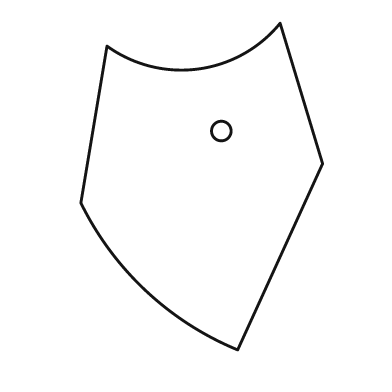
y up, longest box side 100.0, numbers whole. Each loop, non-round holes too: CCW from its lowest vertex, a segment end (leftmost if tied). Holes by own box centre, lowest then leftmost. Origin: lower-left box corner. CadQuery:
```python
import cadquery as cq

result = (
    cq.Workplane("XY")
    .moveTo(48.0, 0.0)
    .lineTo(74.0, 57.0)
    .lineTo(61.0, 100.0)
    .threePointArc((36.0, 86.0), (8.0, 93.0))
    .lineTo(0.0, 45.0)
    .threePointArc((20.0, 18.0), (48.0, 0.0))
    .close()
    .moveTo(43.0, 67.0)
    .circle(3.0)
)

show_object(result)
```